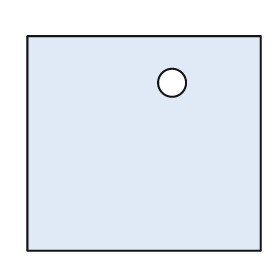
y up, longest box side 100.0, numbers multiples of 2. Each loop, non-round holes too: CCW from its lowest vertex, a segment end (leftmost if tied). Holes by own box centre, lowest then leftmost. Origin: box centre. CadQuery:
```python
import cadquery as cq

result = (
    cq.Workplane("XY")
    .moveTo(-50.0, -46.0)
    .lineTo(50.0, -46.0)
    .lineTo(50.0, 46.0)
    .lineTo(-50.0, 46.0)
    .close()
    .moveTo(12.0, 26.0)
    .circle(6.0)
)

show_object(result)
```